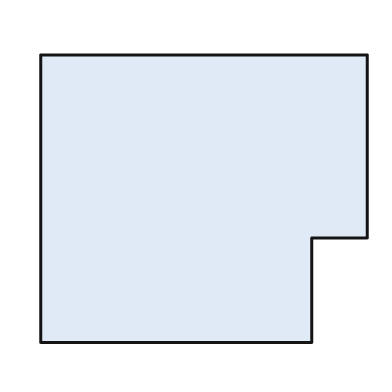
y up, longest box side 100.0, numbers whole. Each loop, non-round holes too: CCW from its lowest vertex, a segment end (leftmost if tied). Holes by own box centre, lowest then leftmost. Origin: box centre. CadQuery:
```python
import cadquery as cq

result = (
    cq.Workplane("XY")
    .moveTo(-50.0, -44.0)
    .lineTo(33.0, -44.0)
    .lineTo(33.0, -12.0)
    .lineTo(50.0, -12.0)
    .lineTo(50.0, 44.0)
    .lineTo(-50.0, 44.0)
    .close()
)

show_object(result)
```